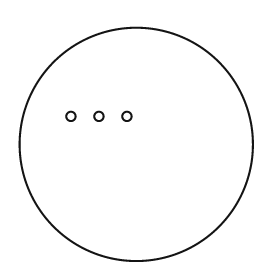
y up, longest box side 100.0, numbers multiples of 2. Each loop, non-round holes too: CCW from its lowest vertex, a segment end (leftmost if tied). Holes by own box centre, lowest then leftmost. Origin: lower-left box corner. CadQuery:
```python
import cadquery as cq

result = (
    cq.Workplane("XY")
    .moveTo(50.0, 50.0)
    .circle(50.0)
    .moveTo(22.0, 62.0)
    .circle(2.0)
    .moveTo(34.0, 62.0)
    .circle(2.0)
    .moveTo(46.0, 62.0)
    .circle(2.0)
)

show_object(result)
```